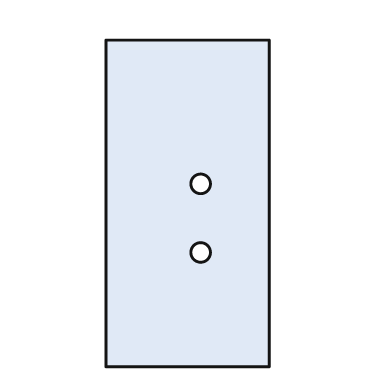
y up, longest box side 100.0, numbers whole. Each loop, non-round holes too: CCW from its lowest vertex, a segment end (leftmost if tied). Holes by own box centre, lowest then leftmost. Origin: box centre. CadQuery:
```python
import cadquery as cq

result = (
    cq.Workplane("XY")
    .moveTo(-25.0, -50.0)
    .lineTo(25.0, -50.0)
    .lineTo(25.0, 50.0)
    .lineTo(-25.0, 50.0)
    .close()
    .moveTo(4.0, -15.0)
    .circle(3.0)
    .moveTo(4.0, 6.0)
    .circle(3.0)
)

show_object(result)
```